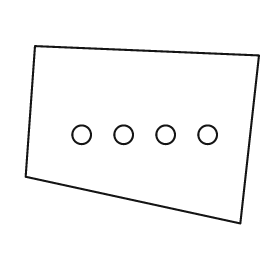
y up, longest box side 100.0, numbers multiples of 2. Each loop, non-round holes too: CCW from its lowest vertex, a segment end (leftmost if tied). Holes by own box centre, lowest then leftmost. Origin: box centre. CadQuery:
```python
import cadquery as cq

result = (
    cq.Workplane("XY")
    .moveTo(42.0, -38.0)
    .lineTo(50.0, 34.0)
    .lineTo(-46.0, 38.0)
    .lineTo(-50.0, -18.0)
    .close()
    .moveTo(-26.0, 0.0)
    .circle(4.0)
    .moveTo(-8.0, 0.0)
    .circle(4.0)
    .moveTo(10.0, 0.0)
    .circle(4.0)
    .moveTo(28.0, 0.0)
    .circle(4.0)
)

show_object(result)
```